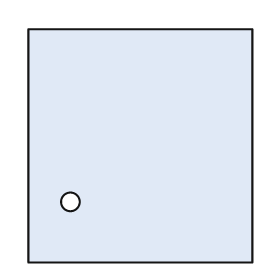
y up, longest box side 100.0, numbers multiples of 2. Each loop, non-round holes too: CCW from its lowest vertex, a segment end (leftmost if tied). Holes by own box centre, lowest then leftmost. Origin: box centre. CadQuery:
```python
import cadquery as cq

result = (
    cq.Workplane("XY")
    .moveTo(-48.0, -50.0)
    .lineTo(48.0, -50.0)
    .lineTo(48.0, 50.0)
    .lineTo(-48.0, 50.0)
    .close()
    .moveTo(-30.0, -24.0)
    .circle(4.0)
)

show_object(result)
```